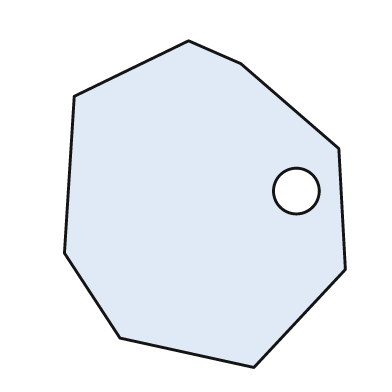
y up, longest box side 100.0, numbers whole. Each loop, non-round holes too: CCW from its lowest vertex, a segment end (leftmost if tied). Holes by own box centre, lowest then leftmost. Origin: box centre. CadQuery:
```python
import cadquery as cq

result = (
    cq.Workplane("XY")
    .moveTo(15.0, -50.0)
    .lineTo(43.0, -20.0)
    .lineTo(41.0, 17.0)
    .lineTo(11.0, 43.0)
    .lineTo(-5.0, 50.0)
    .lineTo(-40.0, 33.0)
    .lineTo(-43.0, -15.0)
    .lineTo(-26.0, -41.0)
    .close()
    .moveTo(28.0, 4.0)
    .circle(7.0)
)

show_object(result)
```